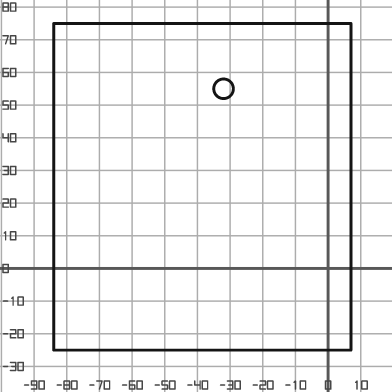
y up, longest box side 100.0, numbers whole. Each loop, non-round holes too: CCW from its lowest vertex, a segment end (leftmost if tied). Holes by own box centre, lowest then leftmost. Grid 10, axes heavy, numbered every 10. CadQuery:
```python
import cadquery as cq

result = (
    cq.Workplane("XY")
    .moveTo(-84.0, -25.0)
    .lineTo(7.0, -25.0)
    .lineTo(7.0, 75.0)
    .lineTo(-84.0, 75.0)
    .close()
    .moveTo(-32.0, 55.0)
    .circle(3.0)
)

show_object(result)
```